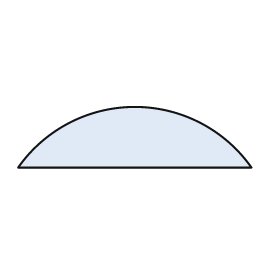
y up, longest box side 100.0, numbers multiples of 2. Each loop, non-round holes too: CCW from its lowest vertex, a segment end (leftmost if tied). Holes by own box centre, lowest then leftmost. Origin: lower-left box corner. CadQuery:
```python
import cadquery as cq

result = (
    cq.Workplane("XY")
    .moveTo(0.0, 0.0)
    .lineTo(100.0, 0.0)
    .threePointArc((50.0, 26.0), (0.0, 0.0))
    .close()
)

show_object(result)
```